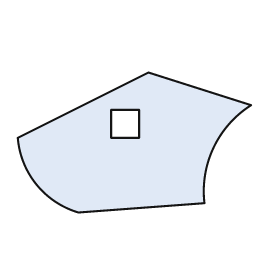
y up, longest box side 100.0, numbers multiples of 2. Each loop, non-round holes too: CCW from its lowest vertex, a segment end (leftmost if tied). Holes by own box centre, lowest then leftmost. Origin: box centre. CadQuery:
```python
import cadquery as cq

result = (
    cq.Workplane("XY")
    .moveTo(-24.0, -30.0)
    .lineTo(30.0, -26.0)
    .threePointArc((34.0, -2.0), (50.0, 16.0))
    .lineTo(6.0, 30.0)
    .lineTo(-50.0, 2.0)
    .threePointArc((-42.0, -18.0), (-24.0, -30.0))
    .close()
    .moveTo(-10.0, 2.0)
    .lineTo(2.0, 2.0)
    .lineTo(2.0, 14.0)
    .lineTo(-10.0, 14.0)
    .close()
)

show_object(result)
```